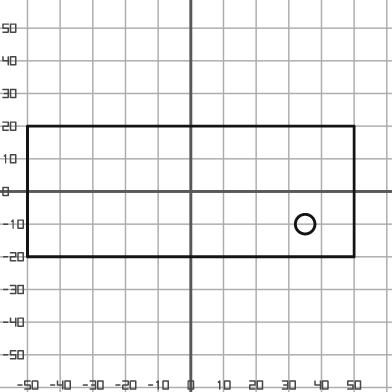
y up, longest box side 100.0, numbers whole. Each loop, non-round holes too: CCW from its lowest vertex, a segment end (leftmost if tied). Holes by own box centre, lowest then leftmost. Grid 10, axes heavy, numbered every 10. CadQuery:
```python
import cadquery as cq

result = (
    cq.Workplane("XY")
    .moveTo(-50.0, -20.0)
    .lineTo(50.0, -20.0)
    .lineTo(50.0, 20.0)
    .lineTo(-50.0, 20.0)
    .close()
    .moveTo(35.0, -10.0)
    .circle(3.0)
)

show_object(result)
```